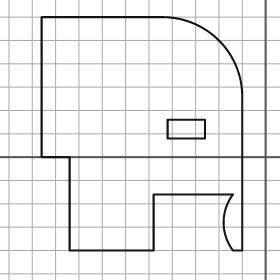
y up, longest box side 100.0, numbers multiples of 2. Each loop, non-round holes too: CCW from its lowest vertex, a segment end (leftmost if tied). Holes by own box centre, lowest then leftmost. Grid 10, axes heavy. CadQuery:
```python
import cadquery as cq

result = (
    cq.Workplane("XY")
    .moveTo(-84.0, -40.0)
    .lineTo(-48.0, -40.0)
    .lineTo(-48.0, -16.0)
    .lineTo(-14.0, -16.0)
    .threePointArc((-18.0, -28.0), (-14.0, -40.0))
    .lineTo(-10.0, -40.0)
    .lineTo(-10.0, 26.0)
    .threePointArc((-20.0, 50.0), (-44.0, 60.0))
    .lineTo(-96.0, 60.0)
    .lineTo(-96.0, 0.0)
    .lineTo(-84.0, 0.0)
    .close()
    .moveTo(-42.0, 8.0)
    .lineTo(-26.0, 8.0)
    .lineTo(-26.0, 16.0)
    .lineTo(-42.0, 16.0)
    .close()
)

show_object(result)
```